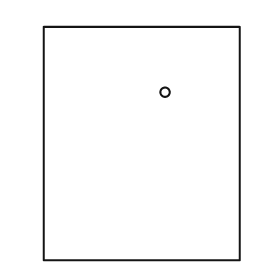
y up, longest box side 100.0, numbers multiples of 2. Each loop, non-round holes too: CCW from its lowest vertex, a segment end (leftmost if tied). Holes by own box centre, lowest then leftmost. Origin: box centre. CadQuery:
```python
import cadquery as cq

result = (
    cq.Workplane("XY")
    .moveTo(-42.0, -50.0)
    .lineTo(42.0, -50.0)
    .lineTo(42.0, 50.0)
    .lineTo(-42.0, 50.0)
    .close()
    .moveTo(10.0, 22.0)
    .circle(2.0)
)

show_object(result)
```